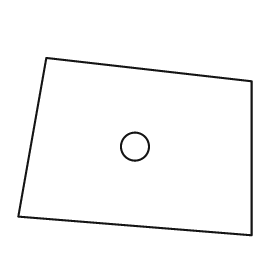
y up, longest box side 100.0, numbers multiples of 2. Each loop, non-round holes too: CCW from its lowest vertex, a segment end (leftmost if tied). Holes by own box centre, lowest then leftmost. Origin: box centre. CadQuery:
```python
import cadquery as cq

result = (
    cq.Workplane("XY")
    .moveTo(50.0, -38.0)
    .lineTo(50.0, 28.0)
    .lineTo(-38.0, 38.0)
    .lineTo(-50.0, -30.0)
    .close()
    .moveTo(0.0, 0.0)
    .circle(6.0)
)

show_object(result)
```